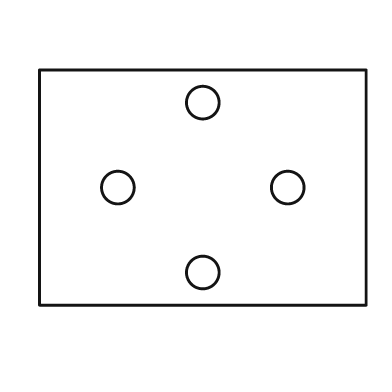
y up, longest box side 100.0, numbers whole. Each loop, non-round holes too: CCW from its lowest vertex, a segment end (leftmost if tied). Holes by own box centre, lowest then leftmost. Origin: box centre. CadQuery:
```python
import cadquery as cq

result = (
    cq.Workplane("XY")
    .moveTo(-50.0, -36.0)
    .lineTo(50.0, -36.0)
    .lineTo(50.0, 36.0)
    .lineTo(-50.0, 36.0)
    .close()
    .moveTo(0.0, -26.0)
    .circle(5.0)
    .moveTo(-26.0, 0.0)
    .circle(5.0)
    .moveTo(26.0, 0.0)
    .circle(5.0)
    .moveTo(0.0, 26.0)
    .circle(5.0)
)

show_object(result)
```